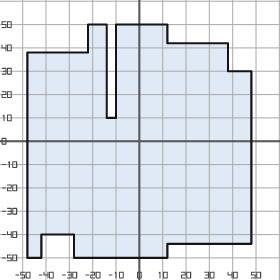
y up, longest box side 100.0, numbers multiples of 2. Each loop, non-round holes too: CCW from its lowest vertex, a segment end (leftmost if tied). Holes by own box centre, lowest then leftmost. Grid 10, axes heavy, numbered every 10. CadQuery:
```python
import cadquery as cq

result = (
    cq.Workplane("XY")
    .moveTo(-48.0, -50.0)
    .lineTo(-42.0, -50.0)
    .lineTo(-42.0, -40.0)
    .lineTo(-28.0, -40.0)
    .lineTo(-28.0, -50.0)
    .lineTo(12.0, -50.0)
    .lineTo(12.0, -44.0)
    .lineTo(48.0, -44.0)
    .lineTo(48.0, 30.0)
    .lineTo(38.0, 30.0)
    .lineTo(38.0, 42.0)
    .lineTo(12.0, 42.0)
    .lineTo(12.0, 50.0)
    .lineTo(-10.0, 50.0)
    .lineTo(-10.0, 10.0)
    .lineTo(-14.0, 10.0)
    .lineTo(-14.0, 50.0)
    .lineTo(-22.0, 50.0)
    .lineTo(-22.0, 38.0)
    .lineTo(-48.0, 38.0)
    .close()
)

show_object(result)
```